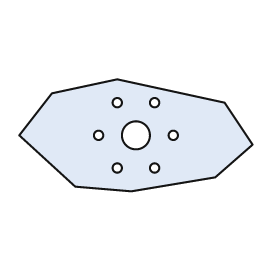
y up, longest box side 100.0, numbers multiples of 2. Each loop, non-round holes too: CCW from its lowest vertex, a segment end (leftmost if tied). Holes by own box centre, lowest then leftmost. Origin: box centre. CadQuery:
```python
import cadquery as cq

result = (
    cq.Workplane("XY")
    .moveTo(-2.0, -24.0)
    .lineTo(34.0, -18.0)
    .lineTo(50.0, -4.0)
    .lineTo(38.0, 14.0)
    .lineTo(-8.0, 24.0)
    .lineTo(-36.0, 18.0)
    .lineTo(-50.0, 0.0)
    .lineTo(-26.0, -22.0)
    .close()
    .moveTo(-8.0, -14.0)
    .circle(2.0)
    .moveTo(8.0, -14.0)
    .circle(2.0)
    .moveTo(-16.0, 0.0)
    .circle(2.0)
    .moveTo(0.0, 0.0)
    .circle(6.0)
    .moveTo(16.0, 0.0)
    .circle(2.0)
    .moveTo(-8.0, 14.0)
    .circle(2.0)
    .moveTo(8.0, 14.0)
    .circle(2.0)
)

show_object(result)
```